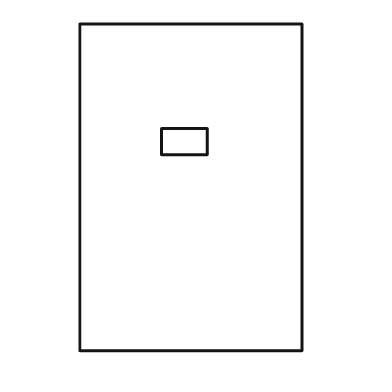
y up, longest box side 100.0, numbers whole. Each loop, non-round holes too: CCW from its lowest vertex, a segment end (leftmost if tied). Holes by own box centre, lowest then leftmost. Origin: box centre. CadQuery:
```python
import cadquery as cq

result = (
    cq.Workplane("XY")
    .moveTo(-34.0, -50.0)
    .lineTo(34.0, -50.0)
    .lineTo(34.0, 50.0)
    .lineTo(-34.0, 50.0)
    .close()
    .moveTo(-9.0, 10.0)
    .lineTo(5.0, 10.0)
    .lineTo(5.0, 18.0)
    .lineTo(-9.0, 18.0)
    .close()
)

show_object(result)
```